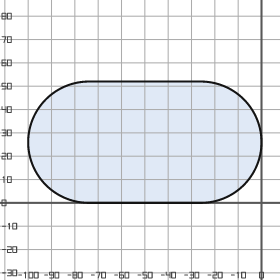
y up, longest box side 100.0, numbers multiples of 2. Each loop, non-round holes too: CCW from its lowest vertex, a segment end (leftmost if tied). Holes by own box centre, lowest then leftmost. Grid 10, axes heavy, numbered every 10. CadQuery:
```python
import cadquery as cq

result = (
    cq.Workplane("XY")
    .moveTo(-74.0, 0.0)
    .lineTo(-26.0, 0.0)
    .threePointArc((0.0, 26.0), (-26.0, 52.0))
    .lineTo(-74.0, 52.0)
    .threePointArc((-100.0, 26.0), (-74.0, 0.0))
    .close()
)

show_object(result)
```